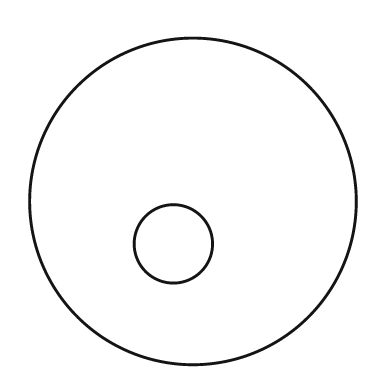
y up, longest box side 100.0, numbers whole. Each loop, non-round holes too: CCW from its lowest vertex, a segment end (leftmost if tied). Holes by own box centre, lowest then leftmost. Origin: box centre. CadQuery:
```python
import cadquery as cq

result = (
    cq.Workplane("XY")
    .moveTo(0.0, 0.0)
    .circle(50.0)
    .moveTo(-6.0, -13.0)
    .circle(12.0)
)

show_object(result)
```